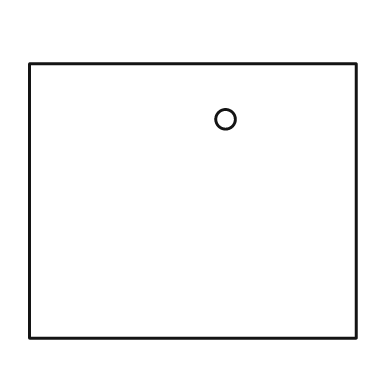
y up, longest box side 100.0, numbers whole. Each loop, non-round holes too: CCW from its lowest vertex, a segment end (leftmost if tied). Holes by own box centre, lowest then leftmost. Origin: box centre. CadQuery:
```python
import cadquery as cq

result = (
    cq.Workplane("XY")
    .moveTo(-50.0, -42.0)
    .lineTo(50.0, -42.0)
    .lineTo(50.0, 42.0)
    .lineTo(-50.0, 42.0)
    .close()
    .moveTo(10.0, 25.0)
    .circle(3.0)
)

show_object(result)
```